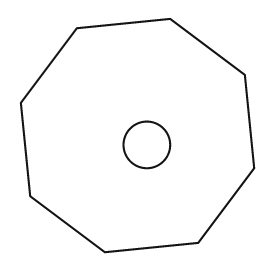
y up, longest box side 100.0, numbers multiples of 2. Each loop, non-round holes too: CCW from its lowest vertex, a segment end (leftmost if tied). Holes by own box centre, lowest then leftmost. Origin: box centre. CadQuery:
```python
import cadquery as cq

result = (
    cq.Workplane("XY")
    .moveTo(-14.0, -50.0)
    .lineTo(26.0, -46.0)
    .lineTo(50.0, -14.0)
    .lineTo(46.0, 26.0)
    .lineTo(14.0, 50.0)
    .lineTo(-26.0, 46.0)
    .lineTo(-50.0, 14.0)
    .lineTo(-46.0, -26.0)
    .close()
    .moveTo(4.0, -4.0)
    .circle(10.0)
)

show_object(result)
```